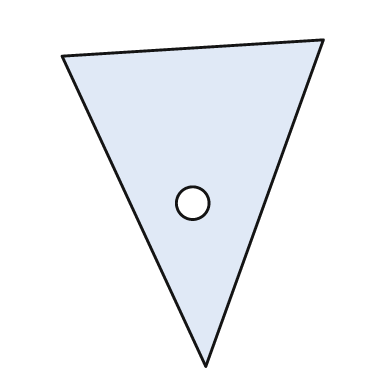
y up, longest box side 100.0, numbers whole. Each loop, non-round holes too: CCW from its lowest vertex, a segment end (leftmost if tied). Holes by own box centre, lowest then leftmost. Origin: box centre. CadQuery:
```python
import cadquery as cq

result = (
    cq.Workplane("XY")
    .moveTo(4.0, -50.0)
    .lineTo(40.0, 50.0)
    .lineTo(-40.0, 45.0)
    .close()
    .moveTo(0.0, 0.0)
    .circle(5.0)
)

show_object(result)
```